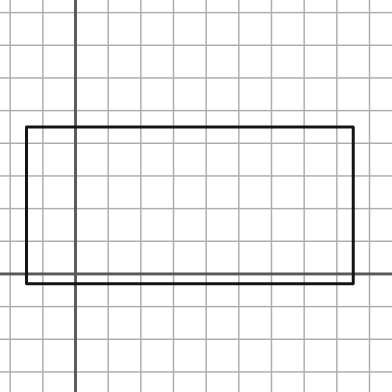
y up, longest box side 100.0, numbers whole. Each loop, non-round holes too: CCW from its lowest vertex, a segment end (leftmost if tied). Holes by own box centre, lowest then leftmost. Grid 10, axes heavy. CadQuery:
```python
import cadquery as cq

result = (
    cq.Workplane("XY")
    .moveTo(-15.0, -3.0)
    .lineTo(85.0, -3.0)
    .lineTo(85.0, 45.0)
    .lineTo(-15.0, 45.0)
    .close()
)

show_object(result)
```